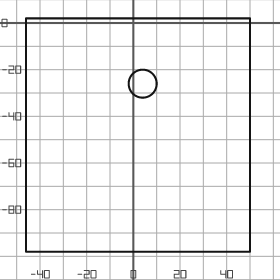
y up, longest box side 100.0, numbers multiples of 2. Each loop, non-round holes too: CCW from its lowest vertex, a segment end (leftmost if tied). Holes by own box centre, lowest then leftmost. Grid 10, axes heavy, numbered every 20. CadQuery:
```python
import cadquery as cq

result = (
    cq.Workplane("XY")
    .moveTo(-46.0, -98.0)
    .lineTo(50.0, -98.0)
    .lineTo(50.0, 2.0)
    .lineTo(-46.0, 2.0)
    .close()
    .moveTo(4.0, -26.0)
    .circle(6.0)
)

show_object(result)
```